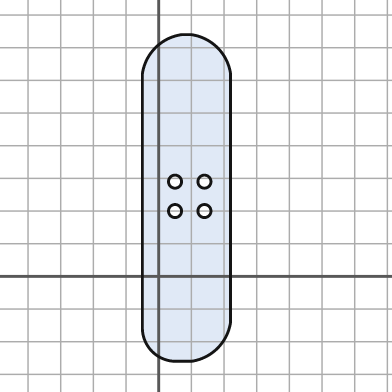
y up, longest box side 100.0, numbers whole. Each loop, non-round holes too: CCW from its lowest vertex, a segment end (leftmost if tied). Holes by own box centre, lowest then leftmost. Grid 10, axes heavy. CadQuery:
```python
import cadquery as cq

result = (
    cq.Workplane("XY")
    .moveTo(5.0, -26.0)
    .lineTo(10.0, -26.0)
    .threePointArc((18.0, -22.0), (22.0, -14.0))
    .lineTo(22.0, 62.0)
    .threePointArc((18.0, 70.0), (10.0, 74.0))
    .lineTo(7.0, 74.0)
    .threePointArc((-1.0, 70.0), (-5.0, 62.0))
    .lineTo(-5.0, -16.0)
    .threePointArc((-2.0, -23.0), (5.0, -26.0))
    .close()
    .moveTo(5.0, 20.0)
    .circle(2.0)
    .moveTo(14.0, 20.0)
    .circle(2.0)
    .moveTo(5.0, 29.0)
    .circle(2.0)
    .moveTo(14.0, 29.0)
    .circle(2.0)
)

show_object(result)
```